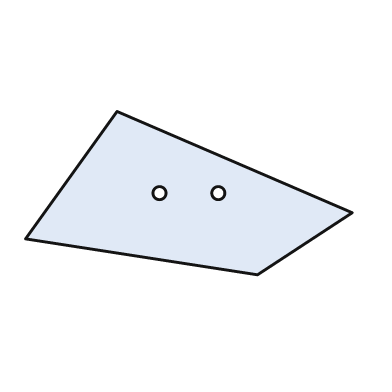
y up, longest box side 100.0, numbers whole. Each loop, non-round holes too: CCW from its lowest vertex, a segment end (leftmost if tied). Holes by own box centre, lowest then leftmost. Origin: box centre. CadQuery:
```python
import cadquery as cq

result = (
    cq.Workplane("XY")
    .moveTo(21.0, -25.0)
    .lineTo(50.0, -6.0)
    .lineTo(-22.0, 25.0)
    .lineTo(-50.0, -14.0)
    .close()
    .moveTo(-9.0, 0.0)
    .circle(2.0)
    .moveTo(9.0, 0.0)
    .circle(2.0)
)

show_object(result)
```